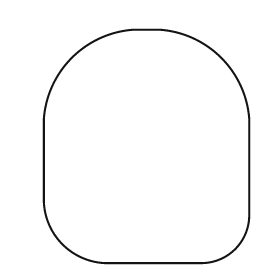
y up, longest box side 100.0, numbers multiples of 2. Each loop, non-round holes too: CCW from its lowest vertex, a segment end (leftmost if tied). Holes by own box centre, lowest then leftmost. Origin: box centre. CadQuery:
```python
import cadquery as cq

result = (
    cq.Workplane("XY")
    .moveTo(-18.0, -50.0)
    .lineTo(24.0, -50.0)
    .threePointArc((38.0, -44.0), (44.0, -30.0))
    .lineTo(44.0, 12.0)
    .threePointArc((32.0, 38.0), (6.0, 50.0))
    .lineTo(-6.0, 50.0)
    .threePointArc((-32.0, 38.0), (-44.0, 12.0))
    .lineTo(-44.0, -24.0)
    .threePointArc((-36.0, -42.0), (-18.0, -50.0))
    .close()
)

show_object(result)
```